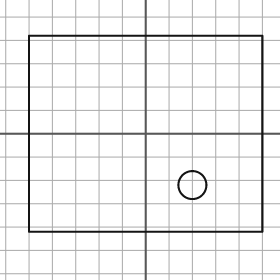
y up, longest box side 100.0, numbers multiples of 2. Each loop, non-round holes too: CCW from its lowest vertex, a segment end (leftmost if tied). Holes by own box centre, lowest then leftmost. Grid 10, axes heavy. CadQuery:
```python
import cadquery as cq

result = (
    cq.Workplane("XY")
    .moveTo(-50.0, -42.0)
    .lineTo(50.0, -42.0)
    .lineTo(50.0, 42.0)
    .lineTo(-50.0, 42.0)
    .close()
    .moveTo(20.0, -22.0)
    .circle(6.0)
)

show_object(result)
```